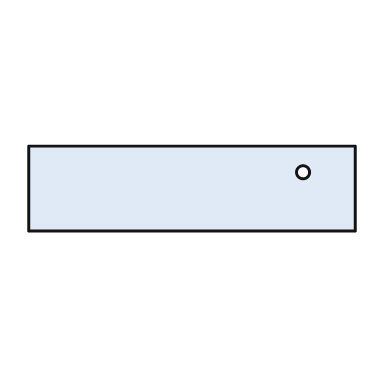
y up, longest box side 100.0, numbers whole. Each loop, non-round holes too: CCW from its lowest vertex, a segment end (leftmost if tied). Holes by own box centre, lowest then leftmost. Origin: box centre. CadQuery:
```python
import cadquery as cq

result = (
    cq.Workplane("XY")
    .moveTo(-50.0, -13.0)
    .lineTo(50.0, -13.0)
    .lineTo(50.0, 13.0)
    .lineTo(-50.0, 13.0)
    .close()
    .moveTo(34.0, 5.0)
    .circle(2.0)
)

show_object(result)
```